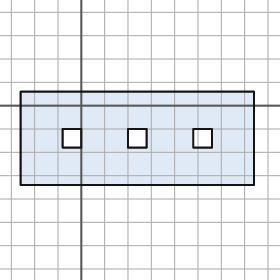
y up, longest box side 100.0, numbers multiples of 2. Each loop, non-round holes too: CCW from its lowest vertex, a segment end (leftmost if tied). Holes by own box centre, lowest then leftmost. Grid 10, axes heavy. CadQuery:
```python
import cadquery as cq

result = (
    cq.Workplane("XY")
    .moveTo(-26.0, -34.0)
    .lineTo(74.0, -34.0)
    .lineTo(74.0, 6.0)
    .lineTo(-26.0, 6.0)
    .close()
    .moveTo(-8.0, -18.0)
    .lineTo(0.0, -18.0)
    .lineTo(0.0, -10.0)
    .lineTo(-8.0, -10.0)
    .close()
    .moveTo(20.0, -18.0)
    .lineTo(28.0, -18.0)
    .lineTo(28.0, -10.0)
    .lineTo(20.0, -10.0)
    .close()
    .moveTo(48.0, -18.0)
    .lineTo(56.0, -18.0)
    .lineTo(56.0, -10.0)
    .lineTo(48.0, -10.0)
    .close()
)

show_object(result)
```